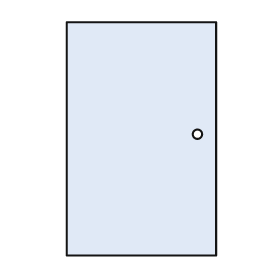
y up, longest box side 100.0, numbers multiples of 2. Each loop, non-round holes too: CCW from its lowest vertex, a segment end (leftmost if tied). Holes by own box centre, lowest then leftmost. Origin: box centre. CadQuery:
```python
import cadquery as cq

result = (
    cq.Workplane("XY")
    .moveTo(-32.0, -50.0)
    .lineTo(32.0, -50.0)
    .lineTo(32.0, 50.0)
    .lineTo(-32.0, 50.0)
    .close()
    .moveTo(24.0, 2.0)
    .circle(2.0)
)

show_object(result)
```